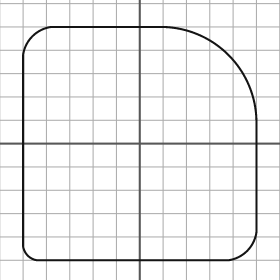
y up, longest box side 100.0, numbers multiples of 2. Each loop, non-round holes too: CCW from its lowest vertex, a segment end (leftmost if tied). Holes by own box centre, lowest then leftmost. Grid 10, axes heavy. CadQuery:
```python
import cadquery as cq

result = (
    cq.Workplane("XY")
    .moveTo(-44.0, -50.0)
    .lineTo(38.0, -50.0)
    .threePointArc((46.0, -46.0), (50.0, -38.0))
    .lineTo(50.0, 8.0)
    .threePointArc((38.0, 38.0), (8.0, 50.0))
    .lineTo(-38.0, 50.0)
    .threePointArc((-46.0, 46.0), (-50.0, 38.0))
    .lineTo(-50.0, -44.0)
    .threePointArc((-48.0, -48.0), (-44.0, -50.0))
    .close()
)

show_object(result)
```